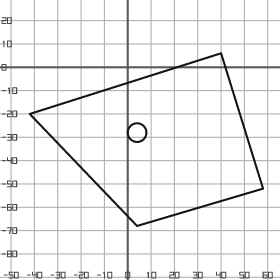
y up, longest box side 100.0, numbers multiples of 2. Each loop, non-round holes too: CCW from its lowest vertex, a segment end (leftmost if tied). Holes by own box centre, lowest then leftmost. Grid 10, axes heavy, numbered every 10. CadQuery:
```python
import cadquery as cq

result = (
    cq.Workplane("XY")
    .moveTo(4.0, -68.0)
    .lineTo(58.0, -52.0)
    .lineTo(40.0, 6.0)
    .lineTo(-42.0, -20.0)
    .close()
    .moveTo(4.0, -28.0)
    .circle(4.0)
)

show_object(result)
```